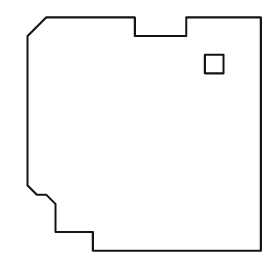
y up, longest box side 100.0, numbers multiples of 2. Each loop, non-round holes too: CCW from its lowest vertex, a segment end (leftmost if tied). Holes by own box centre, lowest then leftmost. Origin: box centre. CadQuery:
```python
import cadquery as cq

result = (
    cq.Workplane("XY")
    .moveTo(-22.0, -50.0)
    .lineTo(50.0, -50.0)
    .lineTo(50.0, 50.0)
    .lineTo(18.0, 50.0)
    .lineTo(18.0, 42.0)
    .lineTo(-4.0, 42.0)
    .lineTo(-4.0, 50.0)
    .lineTo(-42.0, 50.0)
    .lineTo(-50.0, 42.0)
    .lineTo(-50.0, -22.0)
    .lineTo(-46.0, -26.0)
    .lineTo(-42.0, -26.0)
    .lineTo(-38.0, -30.0)
    .lineTo(-38.0, -42.0)
    .lineTo(-22.0, -42.0)
    .close()
    .moveTo(26.0, 26.0)
    .lineTo(34.0, 26.0)
    .lineTo(34.0, 34.0)
    .lineTo(26.0, 34.0)
    .close()
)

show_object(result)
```